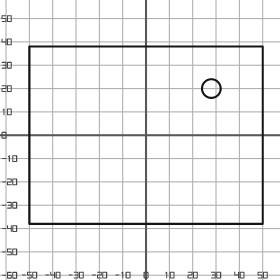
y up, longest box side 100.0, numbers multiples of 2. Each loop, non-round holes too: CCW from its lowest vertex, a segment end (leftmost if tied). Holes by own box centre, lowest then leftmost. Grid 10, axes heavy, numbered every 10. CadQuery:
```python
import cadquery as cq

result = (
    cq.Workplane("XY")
    .moveTo(-50.0, -38.0)
    .lineTo(50.0, -38.0)
    .lineTo(50.0, 38.0)
    .lineTo(-50.0, 38.0)
    .close()
    .moveTo(28.0, 20.0)
    .circle(4.0)
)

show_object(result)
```